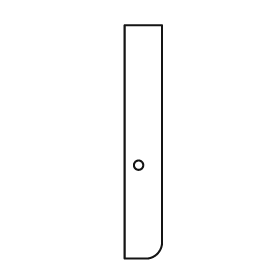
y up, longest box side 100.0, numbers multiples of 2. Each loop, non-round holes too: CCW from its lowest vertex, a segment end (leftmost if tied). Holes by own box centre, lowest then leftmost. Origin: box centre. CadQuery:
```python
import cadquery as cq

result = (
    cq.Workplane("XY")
    .moveTo(-8.0, -50.0)
    .lineTo(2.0, -50.0)
    .threePointArc((6.0, -48.0), (8.0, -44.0))
    .lineTo(8.0, 50.0)
    .lineTo(-8.0, 50.0)
    .close()
    .moveTo(-2.0, -10.0)
    .circle(2.0)
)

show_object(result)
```